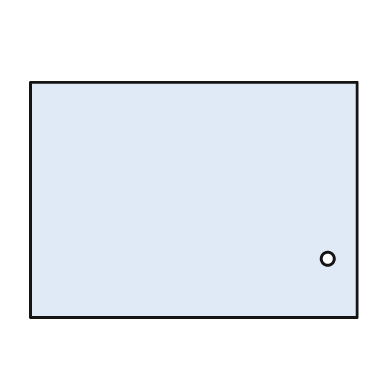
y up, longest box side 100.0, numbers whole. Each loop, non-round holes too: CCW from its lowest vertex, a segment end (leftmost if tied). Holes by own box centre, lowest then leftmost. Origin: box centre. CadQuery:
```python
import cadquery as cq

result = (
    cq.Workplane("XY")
    .moveTo(-50.0, -36.0)
    .lineTo(50.0, -36.0)
    .lineTo(50.0, 36.0)
    .lineTo(-50.0, 36.0)
    .close()
    .moveTo(41.0, -18.0)
    .circle(2.0)
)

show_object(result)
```